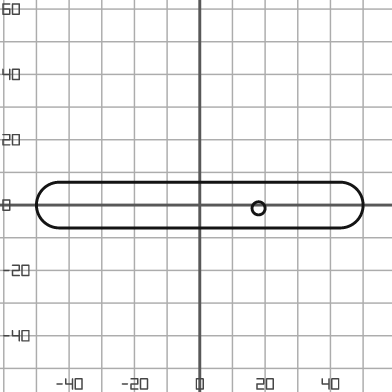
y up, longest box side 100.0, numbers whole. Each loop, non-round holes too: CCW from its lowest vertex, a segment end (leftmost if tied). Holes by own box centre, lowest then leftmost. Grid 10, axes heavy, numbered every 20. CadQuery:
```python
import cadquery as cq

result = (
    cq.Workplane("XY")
    .moveTo(-43.0, -7.0)
    .lineTo(43.0, -7.0)
    .threePointArc((50.0, 0.0), (43.0, 7.0))
    .lineTo(-43.0, 7.0)
    .threePointArc((-50.0, 0.0), (-43.0, -7.0))
    .close()
    .moveTo(18.0, -1.0)
    .circle(2.0)
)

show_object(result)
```